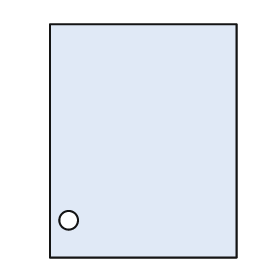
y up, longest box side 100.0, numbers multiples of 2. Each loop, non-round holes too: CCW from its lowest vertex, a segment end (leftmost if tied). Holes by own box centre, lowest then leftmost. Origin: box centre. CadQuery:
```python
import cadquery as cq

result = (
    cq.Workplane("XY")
    .moveTo(-40.0, -50.0)
    .lineTo(40.0, -50.0)
    .lineTo(40.0, 50.0)
    .lineTo(-40.0, 50.0)
    .close()
    .moveTo(-32.0, -34.0)
    .circle(4.0)
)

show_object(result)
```